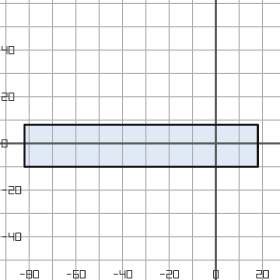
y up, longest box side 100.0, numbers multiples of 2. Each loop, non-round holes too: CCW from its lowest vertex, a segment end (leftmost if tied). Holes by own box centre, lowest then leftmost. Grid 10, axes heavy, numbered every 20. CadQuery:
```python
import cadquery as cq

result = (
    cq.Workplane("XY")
    .moveTo(-82.0, -10.0)
    .lineTo(18.0, -10.0)
    .lineTo(18.0, 8.0)
    .lineTo(-82.0, 8.0)
    .close()
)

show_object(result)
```